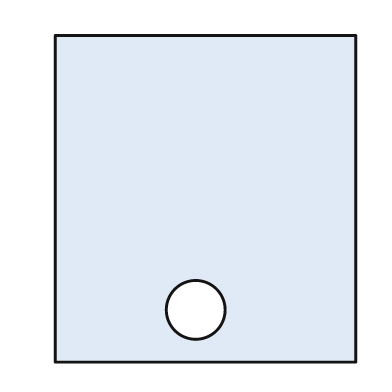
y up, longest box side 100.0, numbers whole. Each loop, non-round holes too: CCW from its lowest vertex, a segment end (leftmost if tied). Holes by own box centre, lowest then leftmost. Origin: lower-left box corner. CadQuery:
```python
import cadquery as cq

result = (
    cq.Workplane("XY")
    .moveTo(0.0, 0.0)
    .lineTo(92.0, 0.0)
    .lineTo(92.0, 100.0)
    .lineTo(0.0, 100.0)
    .close()
    .moveTo(43.0, 16.0)
    .circle(9.0)
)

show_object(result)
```